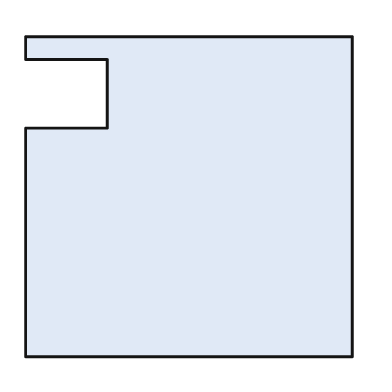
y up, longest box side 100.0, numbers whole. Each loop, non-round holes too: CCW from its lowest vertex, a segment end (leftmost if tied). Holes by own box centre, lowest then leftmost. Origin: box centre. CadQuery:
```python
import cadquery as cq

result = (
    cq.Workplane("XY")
    .moveTo(-50.0, -49.0)
    .lineTo(50.0, -49.0)
    .lineTo(50.0, 49.0)
    .lineTo(-50.0, 49.0)
    .lineTo(-50.0, 42.0)
    .lineTo(-25.0, 42.0)
    .lineTo(-25.0, 21.0)
    .lineTo(-50.0, 21.0)
    .close()
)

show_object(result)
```